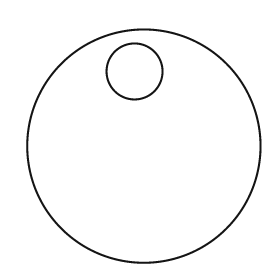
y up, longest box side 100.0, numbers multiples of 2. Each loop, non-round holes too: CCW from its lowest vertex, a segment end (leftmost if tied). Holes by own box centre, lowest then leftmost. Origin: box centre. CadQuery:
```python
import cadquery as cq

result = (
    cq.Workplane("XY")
    .moveTo(0.0, 0.0)
    .circle(50.0)
    .moveTo(-4.0, 32.0)
    .circle(12.0)
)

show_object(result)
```